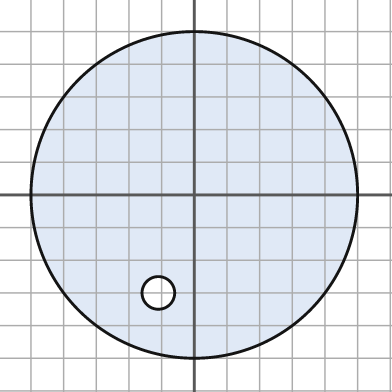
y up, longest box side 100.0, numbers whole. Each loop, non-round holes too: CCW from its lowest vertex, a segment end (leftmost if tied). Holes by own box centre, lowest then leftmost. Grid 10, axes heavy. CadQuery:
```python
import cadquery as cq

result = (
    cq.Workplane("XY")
    .moveTo(0.0, 0.0)
    .circle(50.0)
    .moveTo(-11.0, -30.0)
    .circle(5.0)
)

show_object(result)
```